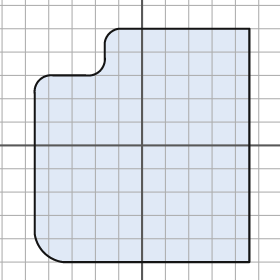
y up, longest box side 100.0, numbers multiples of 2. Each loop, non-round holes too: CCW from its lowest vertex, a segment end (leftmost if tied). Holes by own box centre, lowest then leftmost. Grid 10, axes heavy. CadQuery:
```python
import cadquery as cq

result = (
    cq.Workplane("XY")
    .moveTo(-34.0, -50.0)
    .lineTo(46.0, -50.0)
    .lineTo(46.0, 50.0)
    .lineTo(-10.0, 50.0)
    .threePointArc((-14.0, 48.0), (-16.0, 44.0))
    .lineTo(-16.0, 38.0)
    .threePointArc((-18.0, 32.0), (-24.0, 30.0))
    .lineTo(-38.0, 30.0)
    .threePointArc((-44.0, 28.0), (-46.0, 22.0))
    .lineTo(-46.0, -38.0)
    .threePointArc((-42.0, -46.0), (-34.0, -50.0))
    .close()
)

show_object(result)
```